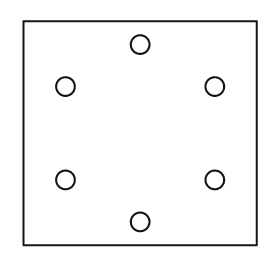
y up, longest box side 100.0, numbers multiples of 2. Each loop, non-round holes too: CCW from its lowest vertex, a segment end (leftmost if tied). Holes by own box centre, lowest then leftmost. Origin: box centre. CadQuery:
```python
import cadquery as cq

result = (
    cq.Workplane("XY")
    .moveTo(-50.0, -48.0)
    .lineTo(50.0, -48.0)
    .lineTo(50.0, 48.0)
    .lineTo(-50.0, 48.0)
    .close()
    .moveTo(0.0, -38.0)
    .circle(4.0)
    .moveTo(-32.0, -20.0)
    .circle(4.0)
    .moveTo(32.0, -20.0)
    .circle(4.0)
    .moveTo(-32.0, 20.0)
    .circle(4.0)
    .moveTo(32.0, 20.0)
    .circle(4.0)
    .moveTo(0.0, 38.0)
    .circle(4.0)
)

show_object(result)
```